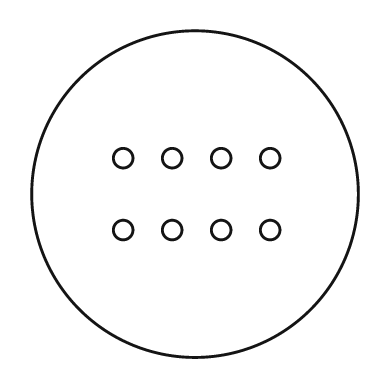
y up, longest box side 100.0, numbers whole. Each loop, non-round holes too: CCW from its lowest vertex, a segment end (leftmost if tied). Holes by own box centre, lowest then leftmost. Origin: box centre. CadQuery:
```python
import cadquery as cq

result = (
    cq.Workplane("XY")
    .moveTo(0.0, 0.0)
    .circle(50.0)
    .moveTo(-22.0, -11.0)
    .circle(3.0)
    .moveTo(-7.0, -11.0)
    .circle(3.0)
    .moveTo(8.0, -11.0)
    .circle(3.0)
    .moveTo(23.0, -11.0)
    .circle(3.0)
    .moveTo(-22.0, 11.0)
    .circle(3.0)
    .moveTo(-7.0, 11.0)
    .circle(3.0)
    .moveTo(8.0, 11.0)
    .circle(3.0)
    .moveTo(23.0, 11.0)
    .circle(3.0)
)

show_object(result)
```